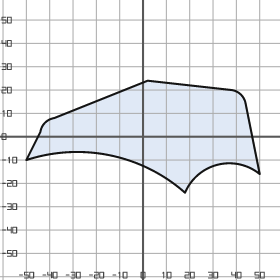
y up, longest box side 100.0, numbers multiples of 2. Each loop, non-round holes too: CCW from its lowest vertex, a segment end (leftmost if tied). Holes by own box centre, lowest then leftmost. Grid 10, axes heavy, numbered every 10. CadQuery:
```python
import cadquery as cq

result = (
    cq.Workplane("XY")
    .moveTo(18.0, -24.0)
    .threePointArc((32.0, -12.0), (50.0, -16.0))
    .lineTo(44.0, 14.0)
    .threePointArc((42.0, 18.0), (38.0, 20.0))
    .lineTo(2.0, 24.0)
    .lineTo(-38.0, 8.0)
    .threePointArc((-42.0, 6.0), (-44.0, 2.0))
    .lineTo(-50.0, -10.0)
    .threePointArc((-14.0, -8.0), (18.0, -24.0))
    .close()
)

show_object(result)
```